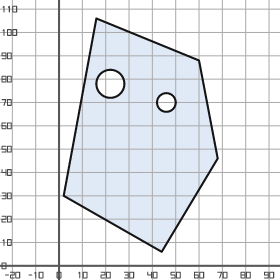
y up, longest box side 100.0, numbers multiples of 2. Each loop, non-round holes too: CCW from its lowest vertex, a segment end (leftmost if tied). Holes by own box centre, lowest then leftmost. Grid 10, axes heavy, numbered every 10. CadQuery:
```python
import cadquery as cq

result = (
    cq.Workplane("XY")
    .moveTo(44.0, 6.0)
    .lineTo(68.0, 46.0)
    .lineTo(60.0, 88.0)
    .lineTo(16.0, 106.0)
    .lineTo(2.0, 30.0)
    .close()
    .moveTo(46.0, 70.0)
    .circle(4.0)
    .moveTo(22.0, 78.0)
    .circle(6.0)
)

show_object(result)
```